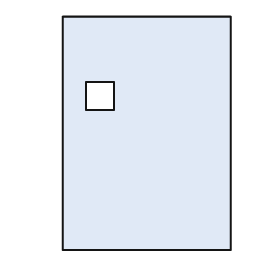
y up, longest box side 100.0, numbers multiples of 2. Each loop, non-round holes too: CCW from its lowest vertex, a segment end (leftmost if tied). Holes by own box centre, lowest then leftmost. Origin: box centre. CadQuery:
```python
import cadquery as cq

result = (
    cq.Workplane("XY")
    .moveTo(-36.0, -50.0)
    .lineTo(36.0, -50.0)
    .lineTo(36.0, 50.0)
    .lineTo(-36.0, 50.0)
    .close()
    .moveTo(-26.0, 10.0)
    .lineTo(-14.0, 10.0)
    .lineTo(-14.0, 22.0)
    .lineTo(-26.0, 22.0)
    .close()
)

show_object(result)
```